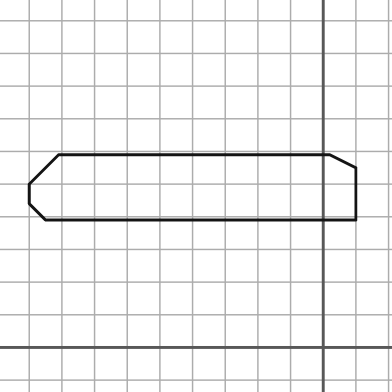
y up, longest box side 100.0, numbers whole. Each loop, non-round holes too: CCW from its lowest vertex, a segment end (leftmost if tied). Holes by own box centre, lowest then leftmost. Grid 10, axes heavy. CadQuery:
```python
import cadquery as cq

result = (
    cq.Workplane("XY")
    .moveTo(-85.0, 39.0)
    .lineTo(10.0, 39.0)
    .lineTo(10.0, 55.0)
    .lineTo(2.0, 59.0)
    .lineTo(-81.0, 59.0)
    .lineTo(-90.0, 50.0)
    .lineTo(-90.0, 44.0)
    .close()
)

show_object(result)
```